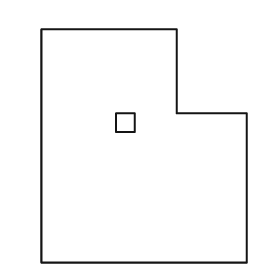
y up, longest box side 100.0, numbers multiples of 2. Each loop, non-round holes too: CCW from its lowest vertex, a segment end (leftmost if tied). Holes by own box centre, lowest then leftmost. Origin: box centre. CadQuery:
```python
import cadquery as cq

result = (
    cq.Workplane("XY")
    .moveTo(-44.0, -50.0)
    .lineTo(44.0, -50.0)
    .lineTo(44.0, 14.0)
    .lineTo(14.0, 14.0)
    .lineTo(14.0, 50.0)
    .lineTo(-44.0, 50.0)
    .close()
    .moveTo(-12.0, 6.0)
    .lineTo(-4.0, 6.0)
    .lineTo(-4.0, 14.0)
    .lineTo(-12.0, 14.0)
    .close()
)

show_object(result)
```